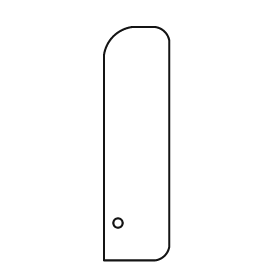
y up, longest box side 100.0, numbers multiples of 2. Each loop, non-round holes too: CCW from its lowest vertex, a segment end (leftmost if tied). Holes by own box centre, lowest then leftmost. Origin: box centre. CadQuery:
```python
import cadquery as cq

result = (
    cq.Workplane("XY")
    .moveTo(-14.0, -50.0)
    .lineTo(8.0, -50.0)
    .threePointArc((12.0, -48.0), (14.0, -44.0))
    .lineTo(14.0, 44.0)
    .threePointArc((12.0, 48.0), (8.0, 50.0))
    .lineTo(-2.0, 50.0)
    .threePointArc((-10.0, 46.0), (-14.0, 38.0))
    .close()
    .moveTo(-8.0, -34.0)
    .circle(2.0)
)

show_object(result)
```